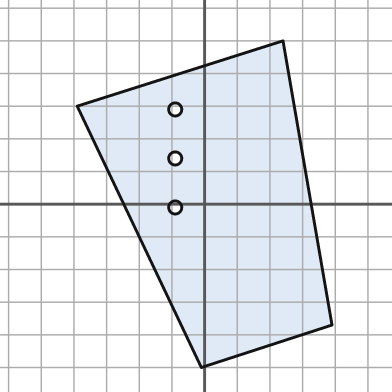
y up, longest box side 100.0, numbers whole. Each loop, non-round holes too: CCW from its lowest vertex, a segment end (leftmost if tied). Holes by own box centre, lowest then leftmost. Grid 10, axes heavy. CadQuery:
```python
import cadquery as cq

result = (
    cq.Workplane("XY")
    .moveTo(-1.0, -50.0)
    .lineTo(39.0, -37.0)
    .lineTo(24.0, 50.0)
    .lineTo(-39.0, 30.0)
    .close()
    .moveTo(-9.0, -1.0)
    .circle(2.0)
    .moveTo(-9.0, 14.0)
    .circle(2.0)
    .moveTo(-9.0, 29.0)
    .circle(2.0)
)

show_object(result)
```